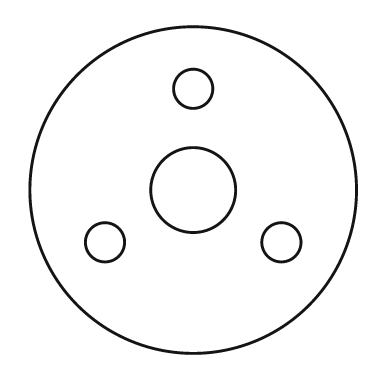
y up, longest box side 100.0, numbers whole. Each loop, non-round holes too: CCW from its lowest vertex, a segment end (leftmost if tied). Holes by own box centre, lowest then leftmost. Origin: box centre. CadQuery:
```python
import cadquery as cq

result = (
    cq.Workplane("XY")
    .moveTo(0.0, 0.0)
    .circle(50.0)
    .moveTo(-27.0, -16.0)
    .circle(6.0)
    .moveTo(27.0, -16.0)
    .circle(6.0)
    .moveTo(0.0, 0.0)
    .circle(13.0)
    .moveTo(0.0, 31.0)
    .circle(6.0)
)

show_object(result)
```